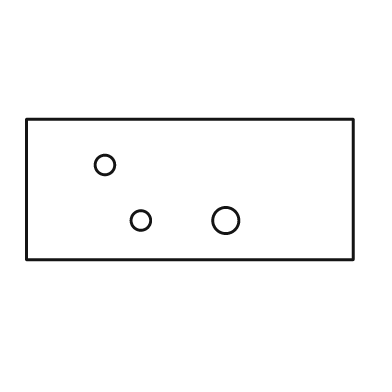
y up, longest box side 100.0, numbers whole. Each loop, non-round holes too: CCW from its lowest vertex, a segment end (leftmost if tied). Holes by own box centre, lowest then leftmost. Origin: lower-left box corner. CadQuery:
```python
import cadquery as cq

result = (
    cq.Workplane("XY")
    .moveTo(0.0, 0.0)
    .lineTo(100.0, 0.0)
    .lineTo(100.0, 43.0)
    .lineTo(0.0, 43.0)
    .close()
    .moveTo(35.0, 12.0)
    .circle(3.0)
    .moveTo(61.0, 12.0)
    .circle(4.0)
    .moveTo(24.0, 29.0)
    .circle(3.0)
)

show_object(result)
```